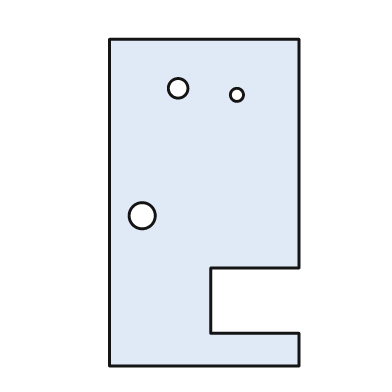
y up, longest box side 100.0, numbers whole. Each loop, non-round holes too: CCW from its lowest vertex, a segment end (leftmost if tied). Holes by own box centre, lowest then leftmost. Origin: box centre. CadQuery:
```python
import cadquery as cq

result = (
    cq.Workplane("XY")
    .moveTo(-29.0, -50.0)
    .lineTo(29.0, -50.0)
    .lineTo(29.0, -40.0)
    .lineTo(2.0, -40.0)
    .lineTo(2.0, -20.0)
    .lineTo(29.0, -20.0)
    .lineTo(29.0, 50.0)
    .lineTo(-29.0, 50.0)
    .close()
    .moveTo(-19.0, -4.0)
    .circle(4.0)
    .moveTo(10.0, 33.0)
    .circle(2.0)
    .moveTo(-8.0, 35.0)
    .circle(3.0)
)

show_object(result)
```